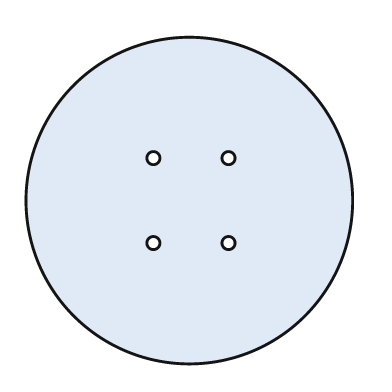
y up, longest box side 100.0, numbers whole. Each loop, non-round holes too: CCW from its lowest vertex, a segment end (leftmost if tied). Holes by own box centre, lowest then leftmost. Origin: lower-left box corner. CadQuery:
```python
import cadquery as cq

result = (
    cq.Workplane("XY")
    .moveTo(50.0, 50.0)
    .circle(50.0)
    .moveTo(39.0, 37.0)
    .circle(2.0)
    .moveTo(62.0, 37.0)
    .circle(2.0)
    .moveTo(39.0, 63.0)
    .circle(2.0)
    .moveTo(62.0, 63.0)
    .circle(2.0)
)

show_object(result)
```